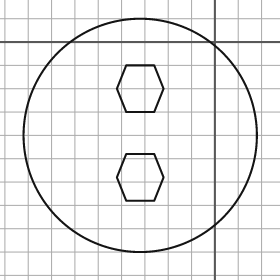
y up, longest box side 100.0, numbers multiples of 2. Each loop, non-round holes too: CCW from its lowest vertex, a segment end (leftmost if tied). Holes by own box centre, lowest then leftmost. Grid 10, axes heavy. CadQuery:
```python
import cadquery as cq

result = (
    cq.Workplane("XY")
    .moveTo(-32.0, -40.0)
    .circle(50.0)
    .moveTo(-38.0, -68.0)
    .lineTo(-26.0, -68.0)
    .lineTo(-22.0, -58.0)
    .lineTo(-26.0, -48.0)
    .lineTo(-38.0, -48.0)
    .lineTo(-42.0, -58.0)
    .close()
    .moveTo(-38.0, -30.0)
    .lineTo(-26.0, -30.0)
    .lineTo(-22.0, -20.0)
    .lineTo(-26.0, -10.0)
    .lineTo(-38.0, -10.0)
    .lineTo(-42.0, -20.0)
    .close()
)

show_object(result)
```